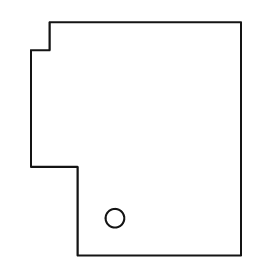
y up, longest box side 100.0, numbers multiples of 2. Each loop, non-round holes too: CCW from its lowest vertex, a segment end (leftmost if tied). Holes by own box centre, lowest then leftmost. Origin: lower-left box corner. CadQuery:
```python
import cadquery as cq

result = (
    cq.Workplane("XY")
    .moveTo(20.0, 0.0)
    .lineTo(90.0, 0.0)
    .lineTo(90.0, 100.0)
    .lineTo(8.0, 100.0)
    .lineTo(8.0, 88.0)
    .lineTo(0.0, 88.0)
    .lineTo(0.0, 38.0)
    .lineTo(20.0, 38.0)
    .close()
    .moveTo(36.0, 16.0)
    .circle(4.0)
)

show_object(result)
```